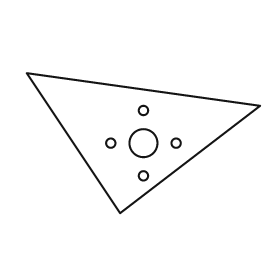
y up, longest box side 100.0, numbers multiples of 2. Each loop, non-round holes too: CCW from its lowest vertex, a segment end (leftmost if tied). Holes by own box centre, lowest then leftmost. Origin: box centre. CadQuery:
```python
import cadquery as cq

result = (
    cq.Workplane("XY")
    .moveTo(-10.0, -30.0)
    .lineTo(50.0, 16.0)
    .lineTo(-50.0, 30.0)
    .close()
    .moveTo(0.0, -14.0)
    .circle(2.0)
    .moveTo(-14.0, 0.0)
    .circle(2.0)
    .moveTo(0.0, 0.0)
    .circle(6.0)
    .moveTo(14.0, 0.0)
    .circle(2.0)
    .moveTo(0.0, 14.0)
    .circle(2.0)
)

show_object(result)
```